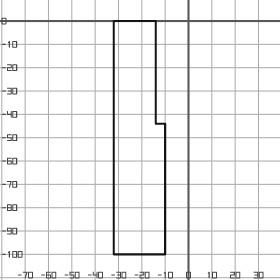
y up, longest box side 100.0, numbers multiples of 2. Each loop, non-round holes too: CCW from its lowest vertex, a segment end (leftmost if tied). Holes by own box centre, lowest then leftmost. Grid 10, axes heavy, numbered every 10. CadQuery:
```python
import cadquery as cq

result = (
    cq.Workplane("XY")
    .moveTo(-32.0, -100.0)
    .lineTo(-10.0, -100.0)
    .lineTo(-10.0, -44.0)
    .lineTo(-14.0, -44.0)
    .lineTo(-14.0, 0.0)
    .lineTo(-32.0, 0.0)
    .close()
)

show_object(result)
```